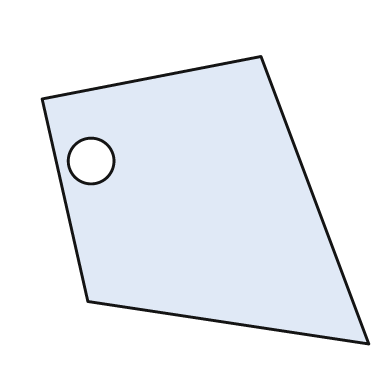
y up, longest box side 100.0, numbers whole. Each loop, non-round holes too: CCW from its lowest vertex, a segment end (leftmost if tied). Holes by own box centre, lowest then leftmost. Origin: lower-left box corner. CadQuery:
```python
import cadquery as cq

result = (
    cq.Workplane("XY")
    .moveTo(100.0, 0.0)
    .lineTo(67.0, 88.0)
    .lineTo(0.0, 75.0)
    .lineTo(14.0, 13.0)
    .close()
    .moveTo(15.0, 56.0)
    .circle(7.0)
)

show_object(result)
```